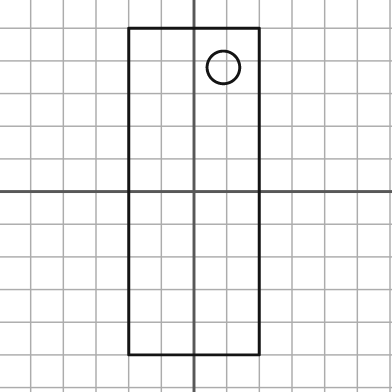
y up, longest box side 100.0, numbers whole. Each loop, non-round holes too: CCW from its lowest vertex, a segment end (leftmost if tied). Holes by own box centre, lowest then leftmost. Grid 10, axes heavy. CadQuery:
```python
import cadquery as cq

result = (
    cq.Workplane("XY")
    .moveTo(-20.0, -50.0)
    .lineTo(20.0, -50.0)
    .lineTo(20.0, 50.0)
    .lineTo(-20.0, 50.0)
    .close()
    .moveTo(9.0, 38.0)
    .circle(5.0)
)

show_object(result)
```